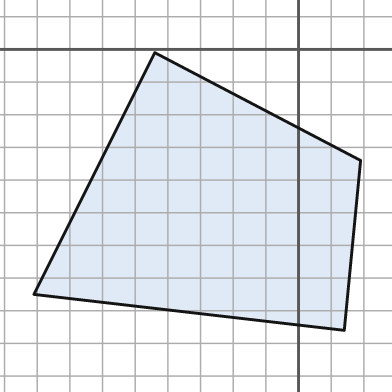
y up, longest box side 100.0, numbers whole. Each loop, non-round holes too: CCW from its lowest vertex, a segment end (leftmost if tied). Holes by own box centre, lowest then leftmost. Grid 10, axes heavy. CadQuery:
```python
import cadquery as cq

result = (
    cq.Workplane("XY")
    .moveTo(14.0, -86.0)
    .lineTo(19.0, -34.0)
    .lineTo(-44.0, -1.0)
    .lineTo(-81.0, -75.0)
    .close()
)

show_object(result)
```